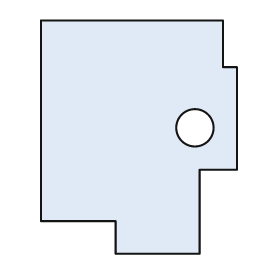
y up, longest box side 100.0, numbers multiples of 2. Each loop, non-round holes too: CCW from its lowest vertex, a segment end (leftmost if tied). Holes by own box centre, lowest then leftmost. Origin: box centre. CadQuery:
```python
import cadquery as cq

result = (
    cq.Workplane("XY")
    .moveTo(-10.0, -50.0)
    .lineTo(26.0, -50.0)
    .lineTo(26.0, -14.0)
    .lineTo(42.0, -14.0)
    .lineTo(42.0, 30.0)
    .lineTo(36.0, 30.0)
    .lineTo(36.0, 50.0)
    .lineTo(-42.0, 50.0)
    .lineTo(-42.0, -36.0)
    .lineTo(-10.0, -36.0)
    .close()
    .moveTo(24.0, 4.0)
    .circle(8.0)
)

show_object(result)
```